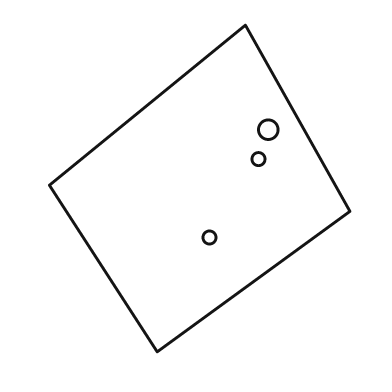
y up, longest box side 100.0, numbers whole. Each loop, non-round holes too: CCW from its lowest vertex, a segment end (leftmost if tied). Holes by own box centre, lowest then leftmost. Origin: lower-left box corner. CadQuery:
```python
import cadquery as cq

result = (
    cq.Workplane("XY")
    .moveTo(33.0, 0.0)
    .lineTo(92.0, 43.0)
    .lineTo(60.0, 100.0)
    .lineTo(0.0, 51.0)
    .close()
    .moveTo(49.0, 35.0)
    .circle(2.0)
    .moveTo(64.0, 59.0)
    .circle(2.0)
    .moveTo(67.0, 68.0)
    .circle(3.0)
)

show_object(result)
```